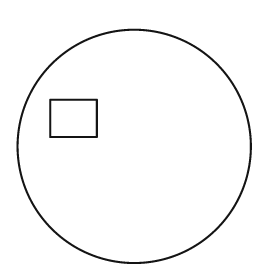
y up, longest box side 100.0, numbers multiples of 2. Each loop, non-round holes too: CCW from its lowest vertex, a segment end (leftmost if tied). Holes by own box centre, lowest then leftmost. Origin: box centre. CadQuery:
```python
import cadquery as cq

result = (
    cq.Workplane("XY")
    .moveTo(0.0, 0.0)
    .circle(50.0)
    .moveTo(-36.0, 4.0)
    .lineTo(-16.0, 4.0)
    .lineTo(-16.0, 20.0)
    .lineTo(-36.0, 20.0)
    .close()
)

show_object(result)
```